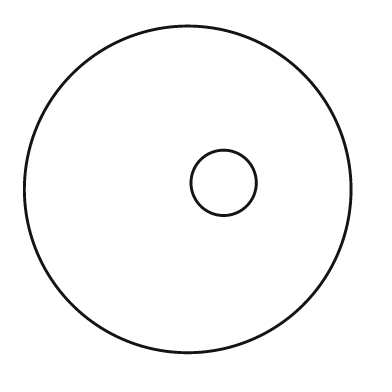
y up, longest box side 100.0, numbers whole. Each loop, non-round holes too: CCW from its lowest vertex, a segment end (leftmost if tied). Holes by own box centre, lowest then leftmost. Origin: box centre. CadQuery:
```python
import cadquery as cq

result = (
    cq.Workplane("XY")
    .moveTo(0.0, 0.0)
    .circle(50.0)
    .moveTo(11.0, 2.0)
    .circle(10.0)
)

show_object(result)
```